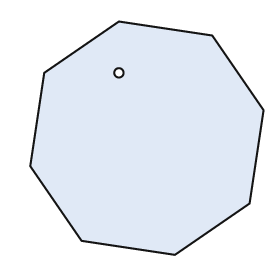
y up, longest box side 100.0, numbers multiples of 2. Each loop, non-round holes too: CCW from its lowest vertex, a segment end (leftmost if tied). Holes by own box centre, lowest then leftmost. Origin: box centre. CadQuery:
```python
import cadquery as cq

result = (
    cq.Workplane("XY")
    .moveTo(12.0, -50.0)
    .lineTo(44.0, -28.0)
    .lineTo(50.0, 12.0)
    .lineTo(28.0, 44.0)
    .lineTo(-12.0, 50.0)
    .lineTo(-44.0, 28.0)
    .lineTo(-50.0, -12.0)
    .lineTo(-28.0, -44.0)
    .close()
    .moveTo(-12.0, 28.0)
    .circle(2.0)
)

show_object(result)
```